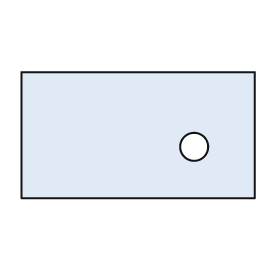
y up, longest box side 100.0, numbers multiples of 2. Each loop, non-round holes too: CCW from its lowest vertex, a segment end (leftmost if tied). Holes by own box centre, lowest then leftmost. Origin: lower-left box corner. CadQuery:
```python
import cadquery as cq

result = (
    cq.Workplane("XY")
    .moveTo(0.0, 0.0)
    .lineTo(100.0, 0.0)
    .lineTo(100.0, 54.0)
    .lineTo(0.0, 54.0)
    .close()
    .moveTo(74.0, 22.0)
    .circle(6.0)
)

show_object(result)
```